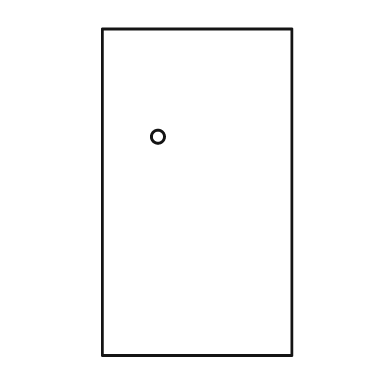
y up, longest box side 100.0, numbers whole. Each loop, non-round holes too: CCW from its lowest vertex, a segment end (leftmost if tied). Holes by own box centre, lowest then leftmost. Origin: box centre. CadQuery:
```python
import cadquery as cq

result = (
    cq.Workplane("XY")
    .moveTo(-29.0, -50.0)
    .lineTo(29.0, -50.0)
    .lineTo(29.0, 50.0)
    .lineTo(-29.0, 50.0)
    .close()
    .moveTo(-12.0, 17.0)
    .circle(2.0)
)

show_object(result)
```